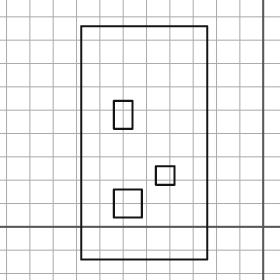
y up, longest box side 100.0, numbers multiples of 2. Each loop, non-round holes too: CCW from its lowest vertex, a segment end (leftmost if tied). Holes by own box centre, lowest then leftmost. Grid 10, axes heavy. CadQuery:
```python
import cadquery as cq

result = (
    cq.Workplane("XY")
    .moveTo(-78.0, -14.0)
    .lineTo(-24.0, -14.0)
    .lineTo(-24.0, 86.0)
    .lineTo(-78.0, 86.0)
    .close()
    .moveTo(-64.0, 4.0)
    .lineTo(-52.0, 4.0)
    .lineTo(-52.0, 16.0)
    .lineTo(-64.0, 16.0)
    .close()
    .moveTo(-46.0, 18.0)
    .lineTo(-38.0, 18.0)
    .lineTo(-38.0, 26.0)
    .lineTo(-46.0, 26.0)
    .close()
    .moveTo(-64.0, 42.0)
    .lineTo(-56.0, 42.0)
    .lineTo(-56.0, 54.0)
    .lineTo(-64.0, 54.0)
    .close()
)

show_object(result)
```